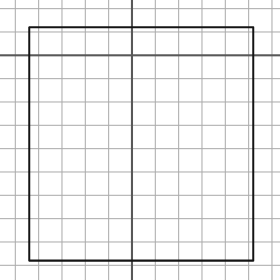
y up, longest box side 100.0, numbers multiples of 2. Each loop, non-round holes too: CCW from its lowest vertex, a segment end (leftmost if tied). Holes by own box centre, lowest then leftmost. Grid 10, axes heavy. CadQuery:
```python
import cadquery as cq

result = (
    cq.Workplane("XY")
    .moveTo(-44.0, -88.0)
    .lineTo(52.0, -88.0)
    .lineTo(52.0, 12.0)
    .lineTo(-44.0, 12.0)
    .close()
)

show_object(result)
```